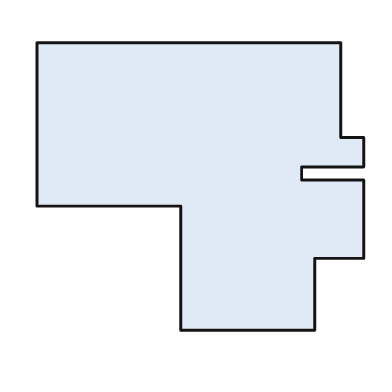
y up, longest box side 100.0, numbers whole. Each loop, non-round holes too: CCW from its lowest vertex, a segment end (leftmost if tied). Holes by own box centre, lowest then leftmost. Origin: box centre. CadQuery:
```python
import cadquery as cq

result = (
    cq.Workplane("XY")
    .moveTo(-6.0, -44.0)
    .lineTo(35.0, -44.0)
    .lineTo(35.0, -22.0)
    .lineTo(50.0, -22.0)
    .lineTo(50.0, 2.0)
    .lineTo(31.0, 2.0)
    .lineTo(31.0, 6.0)
    .lineTo(50.0, 6.0)
    .lineTo(50.0, 15.0)
    .lineTo(43.0, 15.0)
    .lineTo(43.0, 44.0)
    .lineTo(-50.0, 44.0)
    .lineTo(-50.0, -6.0)
    .lineTo(-6.0, -6.0)
    .close()
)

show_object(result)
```